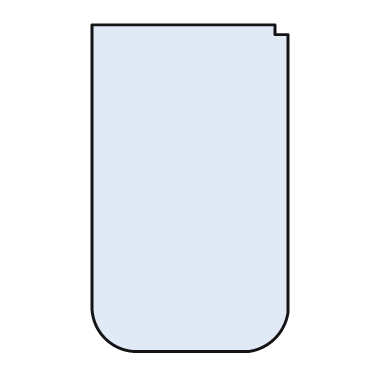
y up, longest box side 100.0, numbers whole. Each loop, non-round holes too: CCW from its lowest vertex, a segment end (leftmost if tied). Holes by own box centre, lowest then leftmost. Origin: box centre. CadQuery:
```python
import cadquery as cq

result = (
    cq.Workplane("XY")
    .moveTo(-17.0, -50.0)
    .lineTo(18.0, -50.0)
    .threePointArc((26.0, -46.0), (30.0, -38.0))
    .lineTo(30.0, 47.0)
    .lineTo(26.0, 47.0)
    .lineTo(26.0, 50.0)
    .lineTo(-30.0, 50.0)
    .lineTo(-30.0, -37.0)
    .threePointArc((-26.0, -46.0), (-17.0, -50.0))
    .close()
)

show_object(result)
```